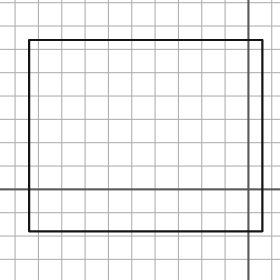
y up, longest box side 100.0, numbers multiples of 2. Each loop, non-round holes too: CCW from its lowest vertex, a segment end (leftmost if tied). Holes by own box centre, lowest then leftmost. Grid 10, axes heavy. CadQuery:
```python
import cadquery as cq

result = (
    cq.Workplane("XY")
    .moveTo(-94.0, -18.0)
    .lineTo(6.0, -18.0)
    .lineTo(6.0, 64.0)
    .lineTo(-94.0, 64.0)
    .close()
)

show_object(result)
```